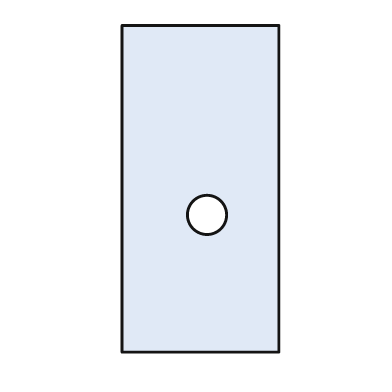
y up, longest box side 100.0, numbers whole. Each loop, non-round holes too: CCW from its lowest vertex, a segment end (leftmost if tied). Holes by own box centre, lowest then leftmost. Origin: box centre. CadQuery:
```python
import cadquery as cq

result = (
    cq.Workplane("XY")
    .moveTo(-24.0, -50.0)
    .lineTo(24.0, -50.0)
    .lineTo(24.0, 50.0)
    .lineTo(-24.0, 50.0)
    .close()
    .moveTo(2.0, -8.0)
    .circle(6.0)
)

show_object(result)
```